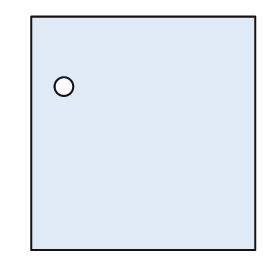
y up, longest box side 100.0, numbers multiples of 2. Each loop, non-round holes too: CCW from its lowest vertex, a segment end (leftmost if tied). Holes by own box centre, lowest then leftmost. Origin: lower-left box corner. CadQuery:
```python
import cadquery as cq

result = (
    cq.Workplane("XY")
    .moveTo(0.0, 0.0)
    .lineTo(96.0, 0.0)
    .lineTo(96.0, 100.0)
    .lineTo(0.0, 100.0)
    .close()
    .moveTo(14.0, 70.0)
    .circle(4.0)
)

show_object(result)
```